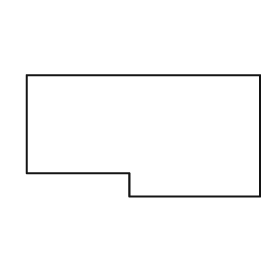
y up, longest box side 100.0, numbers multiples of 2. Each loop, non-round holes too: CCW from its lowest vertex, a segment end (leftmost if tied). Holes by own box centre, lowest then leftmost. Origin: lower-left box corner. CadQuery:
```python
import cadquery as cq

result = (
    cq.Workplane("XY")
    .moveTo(44.0, 0.0)
    .lineTo(100.0, 0.0)
    .lineTo(100.0, 52.0)
    .lineTo(0.0, 52.0)
    .lineTo(0.0, 10.0)
    .lineTo(44.0, 10.0)
    .close()
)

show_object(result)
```